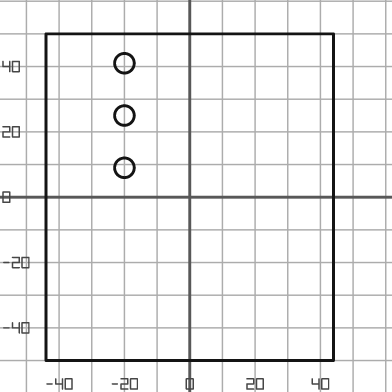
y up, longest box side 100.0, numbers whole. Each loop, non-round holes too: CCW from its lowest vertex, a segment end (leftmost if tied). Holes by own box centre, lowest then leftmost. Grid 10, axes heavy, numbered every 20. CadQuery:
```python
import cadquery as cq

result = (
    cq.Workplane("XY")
    .moveTo(-44.0, -50.0)
    .lineTo(44.0, -50.0)
    .lineTo(44.0, 50.0)
    .lineTo(-44.0, 50.0)
    .close()
    .moveTo(-20.0, 9.0)
    .circle(3.0)
    .moveTo(-20.0, 25.0)
    .circle(3.0)
    .moveTo(-20.0, 41.0)
    .circle(3.0)
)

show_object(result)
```